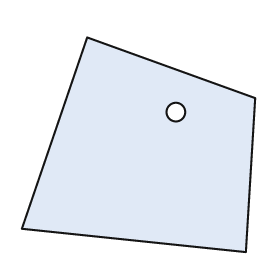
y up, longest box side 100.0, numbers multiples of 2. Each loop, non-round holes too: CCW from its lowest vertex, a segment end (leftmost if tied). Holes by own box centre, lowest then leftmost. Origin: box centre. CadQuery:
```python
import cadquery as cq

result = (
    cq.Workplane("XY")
    .moveTo(46.0, -46.0)
    .lineTo(50.0, 20.0)
    .lineTo(-22.0, 46.0)
    .lineTo(-50.0, -36.0)
    .close()
    .moveTo(16.0, 14.0)
    .circle(4.0)
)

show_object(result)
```